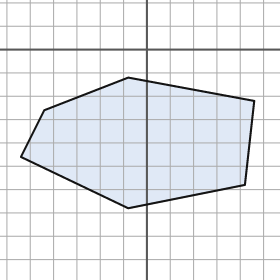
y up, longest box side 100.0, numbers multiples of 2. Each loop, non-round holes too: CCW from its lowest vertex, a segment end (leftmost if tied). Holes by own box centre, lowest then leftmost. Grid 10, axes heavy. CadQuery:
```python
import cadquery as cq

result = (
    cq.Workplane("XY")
    .moveTo(-8.0, -68.0)
    .lineTo(42.0, -58.0)
    .lineTo(46.0, -22.0)
    .lineTo(-8.0, -12.0)
    .lineTo(-44.0, -26.0)
    .lineTo(-54.0, -46.0)
    .close()
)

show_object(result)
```